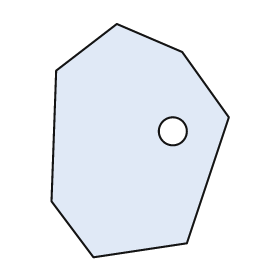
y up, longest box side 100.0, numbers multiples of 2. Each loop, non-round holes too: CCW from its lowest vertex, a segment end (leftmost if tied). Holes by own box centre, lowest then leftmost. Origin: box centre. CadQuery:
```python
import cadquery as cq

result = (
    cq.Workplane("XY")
    .moveTo(-20.0, -50.0)
    .lineTo(20.0, -44.0)
    .lineTo(38.0, 10.0)
    .lineTo(18.0, 38.0)
    .lineTo(-10.0, 50.0)
    .lineTo(-36.0, 30.0)
    .lineTo(-38.0, -26.0)
    .close()
    .moveTo(14.0, 4.0)
    .circle(6.0)
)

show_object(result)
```